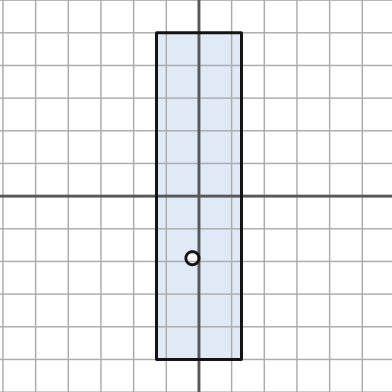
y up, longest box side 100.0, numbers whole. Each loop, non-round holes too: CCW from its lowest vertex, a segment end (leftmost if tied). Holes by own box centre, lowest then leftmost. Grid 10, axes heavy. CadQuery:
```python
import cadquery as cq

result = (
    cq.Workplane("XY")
    .moveTo(-13.0, -50.0)
    .lineTo(13.0, -50.0)
    .lineTo(13.0, 50.0)
    .lineTo(-13.0, 50.0)
    .close()
    .moveTo(-2.0, -19.0)
    .circle(2.0)
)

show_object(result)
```